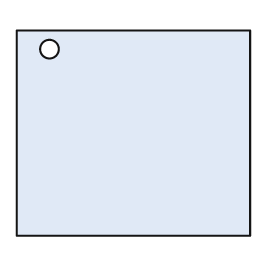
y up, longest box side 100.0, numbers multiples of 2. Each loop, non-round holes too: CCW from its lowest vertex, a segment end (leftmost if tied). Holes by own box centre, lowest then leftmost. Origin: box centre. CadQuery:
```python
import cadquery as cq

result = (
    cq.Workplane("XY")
    .moveTo(-50.0, -44.0)
    .lineTo(50.0, -44.0)
    .lineTo(50.0, 44.0)
    .lineTo(-50.0, 44.0)
    .close()
    .moveTo(-36.0, 36.0)
    .circle(4.0)
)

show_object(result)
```